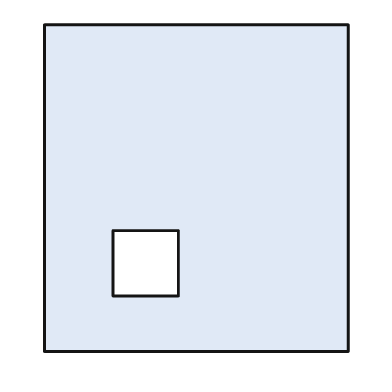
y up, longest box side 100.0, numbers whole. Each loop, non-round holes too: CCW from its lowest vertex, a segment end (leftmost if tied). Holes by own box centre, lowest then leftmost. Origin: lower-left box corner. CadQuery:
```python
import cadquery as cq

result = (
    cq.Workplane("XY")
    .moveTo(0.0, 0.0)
    .lineTo(93.0, 0.0)
    .lineTo(93.0, 100.0)
    .lineTo(0.0, 100.0)
    .close()
    .moveTo(21.0, 17.0)
    .lineTo(41.0, 17.0)
    .lineTo(41.0, 37.0)
    .lineTo(21.0, 37.0)
    .close()
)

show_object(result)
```